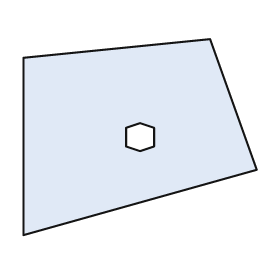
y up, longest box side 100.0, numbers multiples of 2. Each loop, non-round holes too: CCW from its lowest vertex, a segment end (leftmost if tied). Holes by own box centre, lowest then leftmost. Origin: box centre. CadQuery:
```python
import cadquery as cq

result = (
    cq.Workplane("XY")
    .moveTo(-50.0, -42.0)
    .lineTo(50.0, -14.0)
    .lineTo(30.0, 42.0)
    .lineTo(-50.0, 34.0)
    .close()
    .moveTo(0.0, -6.0)
    .lineTo(6.0, -4.0)
    .lineTo(6.0, 4.0)
    .lineTo(0.0, 6.0)
    .lineTo(-6.0, 4.0)
    .lineTo(-6.0, -4.0)
    .close()
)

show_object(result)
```